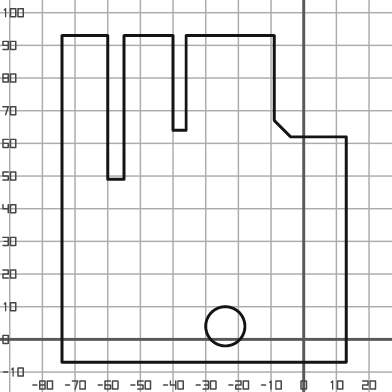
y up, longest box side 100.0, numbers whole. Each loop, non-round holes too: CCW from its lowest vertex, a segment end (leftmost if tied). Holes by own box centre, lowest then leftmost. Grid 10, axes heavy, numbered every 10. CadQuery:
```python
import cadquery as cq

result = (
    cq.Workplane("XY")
    .moveTo(-74.0, -7.0)
    .lineTo(13.0, -7.0)
    .lineTo(13.0, 62.0)
    .lineTo(-4.0, 62.0)
    .lineTo(-9.0, 67.0)
    .lineTo(-9.0, 93.0)
    .lineTo(-36.0, 93.0)
    .lineTo(-36.0, 64.0)
    .lineTo(-40.0, 64.0)
    .lineTo(-40.0, 93.0)
    .lineTo(-55.0, 93.0)
    .lineTo(-55.0, 49.0)
    .lineTo(-60.0, 49.0)
    .lineTo(-60.0, 93.0)
    .lineTo(-74.0, 93.0)
    .close()
    .moveTo(-24.0, 4.0)
    .circle(6.0)
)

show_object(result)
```